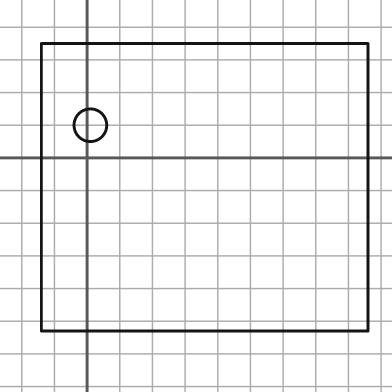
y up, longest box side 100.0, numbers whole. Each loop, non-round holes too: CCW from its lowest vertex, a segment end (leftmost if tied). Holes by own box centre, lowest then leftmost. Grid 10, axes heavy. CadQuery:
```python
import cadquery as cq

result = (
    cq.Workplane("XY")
    .moveTo(-14.0, -53.0)
    .lineTo(86.0, -53.0)
    .lineTo(86.0, 35.0)
    .lineTo(-14.0, 35.0)
    .close()
    .moveTo(1.0, 10.0)
    .circle(5.0)
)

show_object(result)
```